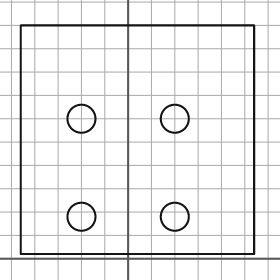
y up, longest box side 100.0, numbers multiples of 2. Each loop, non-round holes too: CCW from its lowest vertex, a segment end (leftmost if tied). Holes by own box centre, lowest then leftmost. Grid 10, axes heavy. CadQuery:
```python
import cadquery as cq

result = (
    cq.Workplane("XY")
    .moveTo(-46.0, 2.0)
    .lineTo(54.0, 2.0)
    .lineTo(54.0, 100.0)
    .lineTo(-46.0, 100.0)
    .close()
    .moveTo(-20.0, 18.0)
    .circle(6.0)
    .moveTo(20.0, 18.0)
    .circle(6.0)
    .moveTo(-20.0, 60.0)
    .circle(6.0)
    .moveTo(20.0, 60.0)
    .circle(6.0)
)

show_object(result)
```